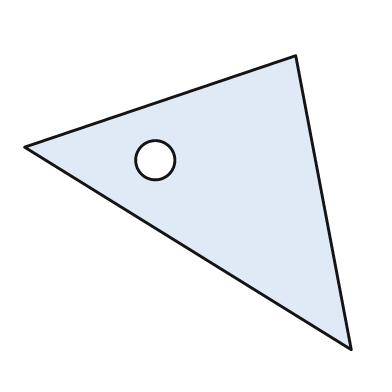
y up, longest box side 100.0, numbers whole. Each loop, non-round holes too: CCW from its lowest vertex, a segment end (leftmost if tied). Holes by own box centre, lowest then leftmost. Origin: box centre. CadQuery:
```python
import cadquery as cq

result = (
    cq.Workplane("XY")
    .moveTo(50.0, -45.0)
    .lineTo(33.0, 45.0)
    .lineTo(-50.0, 17.0)
    .close()
    .moveTo(-10.0, 13.0)
    .circle(6.0)
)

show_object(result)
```